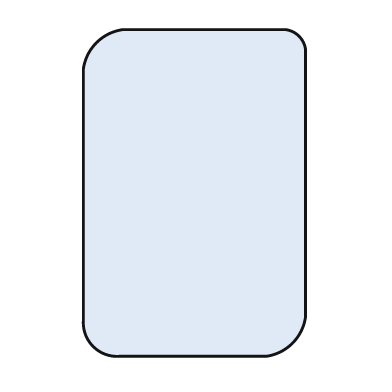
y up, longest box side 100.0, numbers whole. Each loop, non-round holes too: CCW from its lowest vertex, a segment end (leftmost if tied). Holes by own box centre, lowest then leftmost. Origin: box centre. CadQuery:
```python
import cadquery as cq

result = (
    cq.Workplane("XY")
    .moveTo(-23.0, -50.0)
    .lineTo(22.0, -50.0)
    .threePointArc((30.0, -46.0), (34.0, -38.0))
    .lineTo(34.0, 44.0)
    .threePointArc((32.0, 48.0), (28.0, 50.0))
    .lineTo(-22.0, 50.0)
    .threePointArc((-30.0, 46.0), (-34.0, 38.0))
    .lineTo(-34.0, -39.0)
    .threePointArc((-31.0, -47.0), (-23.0, -50.0))
    .close()
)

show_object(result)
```